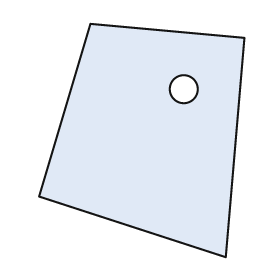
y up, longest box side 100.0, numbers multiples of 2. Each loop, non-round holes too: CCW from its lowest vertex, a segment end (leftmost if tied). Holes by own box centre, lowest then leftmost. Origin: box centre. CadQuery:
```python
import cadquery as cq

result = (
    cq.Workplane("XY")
    .moveTo(36.0, -50.0)
    .lineTo(44.0, 44.0)
    .lineTo(-22.0, 50.0)
    .lineTo(-44.0, -24.0)
    .close()
    .moveTo(18.0, 22.0)
    .circle(6.0)
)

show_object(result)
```